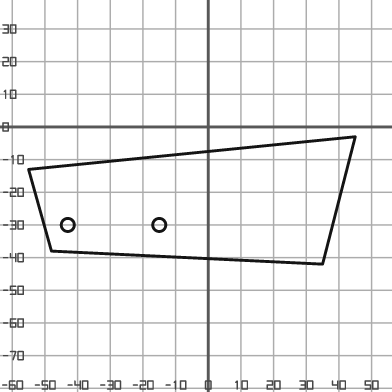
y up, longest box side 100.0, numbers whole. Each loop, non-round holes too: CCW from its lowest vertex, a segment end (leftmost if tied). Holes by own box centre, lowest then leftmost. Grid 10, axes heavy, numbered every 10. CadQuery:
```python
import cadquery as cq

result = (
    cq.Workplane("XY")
    .moveTo(35.0, -42.0)
    .lineTo(45.0, -3.0)
    .lineTo(-55.0, -13.0)
    .lineTo(-48.0, -38.0)
    .close()
    .moveTo(-43.0, -30.0)
    .circle(2.0)
    .moveTo(-15.0, -30.0)
    .circle(2.0)
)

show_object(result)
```